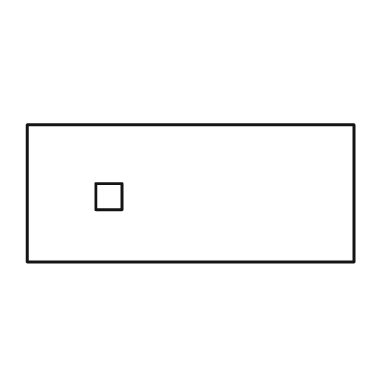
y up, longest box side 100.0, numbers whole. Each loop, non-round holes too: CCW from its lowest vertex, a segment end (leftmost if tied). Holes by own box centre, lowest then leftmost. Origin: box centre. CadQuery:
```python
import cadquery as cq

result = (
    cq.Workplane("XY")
    .moveTo(-50.0, -21.0)
    .lineTo(50.0, -21.0)
    .lineTo(50.0, 21.0)
    .lineTo(-50.0, 21.0)
    .close()
    .moveTo(-29.0, -5.0)
    .lineTo(-21.0, -5.0)
    .lineTo(-21.0, 3.0)
    .lineTo(-29.0, 3.0)
    .close()
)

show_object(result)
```